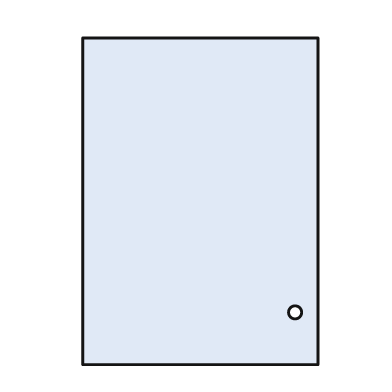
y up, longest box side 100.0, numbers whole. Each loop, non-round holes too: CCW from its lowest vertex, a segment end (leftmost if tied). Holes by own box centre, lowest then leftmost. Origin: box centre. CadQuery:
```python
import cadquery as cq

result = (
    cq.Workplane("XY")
    .moveTo(-36.0, -50.0)
    .lineTo(36.0, -50.0)
    .lineTo(36.0, 50.0)
    .lineTo(-36.0, 50.0)
    .close()
    .moveTo(29.0, -34.0)
    .circle(2.0)
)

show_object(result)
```